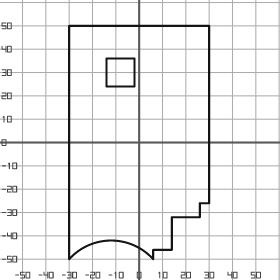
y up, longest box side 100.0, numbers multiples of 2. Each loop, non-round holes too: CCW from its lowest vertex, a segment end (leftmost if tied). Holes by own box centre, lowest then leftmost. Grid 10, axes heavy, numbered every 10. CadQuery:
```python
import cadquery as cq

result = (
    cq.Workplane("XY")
    .moveTo(-30.0, -50.0)
    .threePointArc((-12.0, -42.0), (6.0, -50.0))
    .lineTo(6.0, -46.0)
    .lineTo(14.0, -46.0)
    .lineTo(14.0, -32.0)
    .lineTo(26.0, -32.0)
    .lineTo(26.0, -26.0)
    .lineTo(30.0, -26.0)
    .lineTo(30.0, 50.0)
    .lineTo(-30.0, 50.0)
    .close()
    .moveTo(-14.0, 24.0)
    .lineTo(-2.0, 24.0)
    .lineTo(-2.0, 36.0)
    .lineTo(-14.0, 36.0)
    .close()
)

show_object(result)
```